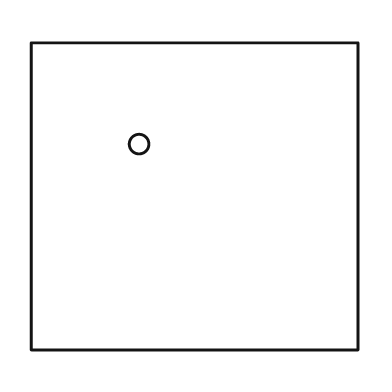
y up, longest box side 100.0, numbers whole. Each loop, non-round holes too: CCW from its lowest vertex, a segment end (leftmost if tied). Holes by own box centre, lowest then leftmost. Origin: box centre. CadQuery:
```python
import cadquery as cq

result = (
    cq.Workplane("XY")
    .moveTo(-50.0, -47.0)
    .lineTo(50.0, -47.0)
    .lineTo(50.0, 47.0)
    .lineTo(-50.0, 47.0)
    .close()
    .moveTo(-17.0, 16.0)
    .circle(3.0)
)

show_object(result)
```